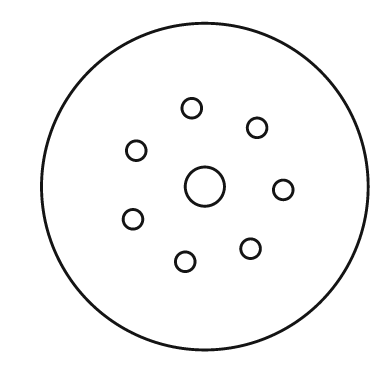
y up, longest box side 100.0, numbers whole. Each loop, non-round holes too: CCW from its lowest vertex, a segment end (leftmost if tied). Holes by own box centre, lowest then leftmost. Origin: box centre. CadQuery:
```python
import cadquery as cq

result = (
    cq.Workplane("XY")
    .moveTo(0.0, 0.0)
    .circle(50.0)
    .moveTo(-6.0, -23.0)
    .circle(3.0)
    .moveTo(14.0, -19.0)
    .circle(3.0)
    .moveTo(-22.0, -10.0)
    .circle(3.0)
    .moveTo(24.0, -1.0)
    .circle(3.0)
    .moveTo(0.0, 0.0)
    .circle(6.0)
    .moveTo(-21.0, 11.0)
    .circle(3.0)
    .moveTo(16.0, 18.0)
    .circle(3.0)
    .moveTo(-4.0, 24.0)
    .circle(3.0)
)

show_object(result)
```